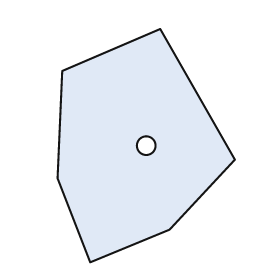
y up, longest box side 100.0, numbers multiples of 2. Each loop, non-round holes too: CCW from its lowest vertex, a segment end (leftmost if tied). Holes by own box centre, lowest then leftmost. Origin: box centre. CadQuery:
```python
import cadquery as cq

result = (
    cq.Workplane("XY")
    .moveTo(-24.0, -50.0)
    .lineTo(10.0, -36.0)
    .lineTo(38.0, -6.0)
    .lineTo(6.0, 50.0)
    .lineTo(-36.0, 32.0)
    .lineTo(-38.0, -14.0)
    .close()
    .moveTo(0.0, 0.0)
    .circle(4.0)
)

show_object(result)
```